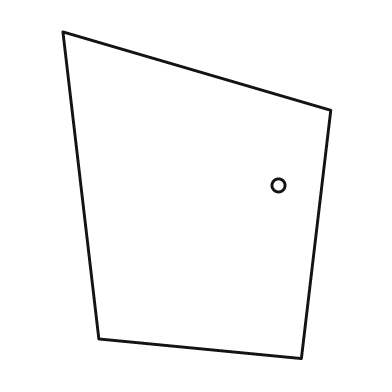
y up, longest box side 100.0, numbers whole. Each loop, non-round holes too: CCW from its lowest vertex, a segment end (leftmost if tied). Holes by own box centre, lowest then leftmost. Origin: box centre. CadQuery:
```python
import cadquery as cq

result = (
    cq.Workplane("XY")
    .moveTo(32.0, -50.0)
    .lineTo(41.0, 26.0)
    .lineTo(-41.0, 50.0)
    .lineTo(-30.0, -44.0)
    .close()
    .moveTo(25.0, 3.0)
    .circle(2.0)
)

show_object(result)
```